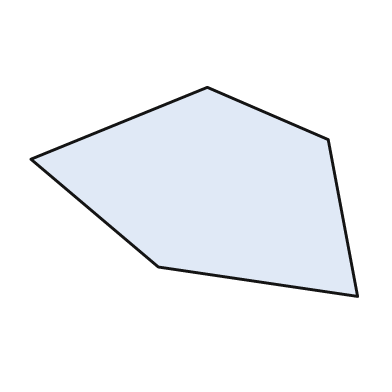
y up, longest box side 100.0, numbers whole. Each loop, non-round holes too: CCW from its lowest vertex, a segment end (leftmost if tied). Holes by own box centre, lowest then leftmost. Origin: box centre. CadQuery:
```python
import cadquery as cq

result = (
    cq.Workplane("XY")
    .moveTo(50.0, -32.0)
    .lineTo(41.0, 16.0)
    .lineTo(4.0, 32.0)
    .lineTo(-50.0, 10.0)
    .lineTo(-11.0, -23.0)
    .close()
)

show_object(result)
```